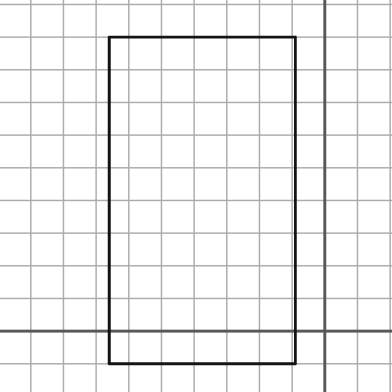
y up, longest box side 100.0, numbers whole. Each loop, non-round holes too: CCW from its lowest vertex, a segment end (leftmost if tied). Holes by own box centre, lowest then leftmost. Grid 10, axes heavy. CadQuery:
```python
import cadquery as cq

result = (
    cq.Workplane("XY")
    .moveTo(-66.0, -10.0)
    .lineTo(-9.0, -10.0)
    .lineTo(-9.0, 90.0)
    .lineTo(-66.0, 90.0)
    .close()
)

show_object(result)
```